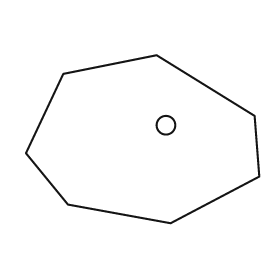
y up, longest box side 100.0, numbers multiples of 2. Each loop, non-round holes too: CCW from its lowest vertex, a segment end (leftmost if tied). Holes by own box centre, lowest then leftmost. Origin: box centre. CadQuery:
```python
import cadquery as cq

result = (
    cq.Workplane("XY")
    .moveTo(12.0, -36.0)
    .lineTo(50.0, -16.0)
    .lineTo(48.0, 10.0)
    .lineTo(6.0, 36.0)
    .lineTo(-34.0, 28.0)
    .lineTo(-50.0, -6.0)
    .lineTo(-32.0, -28.0)
    .close()
    .moveTo(10.0, 6.0)
    .circle(4.0)
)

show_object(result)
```